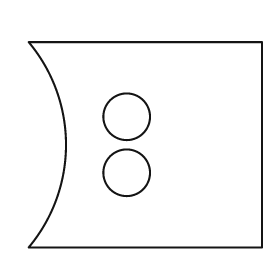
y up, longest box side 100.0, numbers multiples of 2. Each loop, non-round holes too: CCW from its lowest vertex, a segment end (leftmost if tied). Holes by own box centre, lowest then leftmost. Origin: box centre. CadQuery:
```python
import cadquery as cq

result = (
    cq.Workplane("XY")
    .moveTo(-50.0, -44.0)
    .lineTo(50.0, -44.0)
    .lineTo(50.0, 44.0)
    .lineTo(-50.0, 44.0)
    .threePointArc((-34.0, 0.0), (-50.0, -44.0))
    .close()
    .moveTo(-8.0, -12.0)
    .circle(10.0)
    .moveTo(-8.0, 12.0)
    .circle(10.0)
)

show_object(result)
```